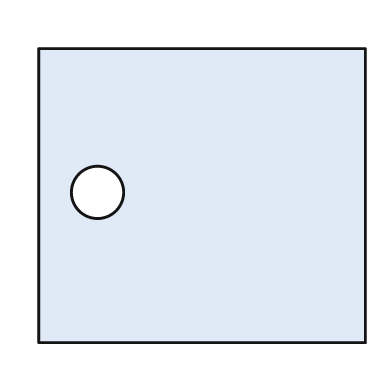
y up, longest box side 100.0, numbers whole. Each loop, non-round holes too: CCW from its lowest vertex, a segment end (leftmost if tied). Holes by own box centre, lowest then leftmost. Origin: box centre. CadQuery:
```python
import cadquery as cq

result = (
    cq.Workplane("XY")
    .moveTo(-50.0, -45.0)
    .lineTo(50.0, -45.0)
    .lineTo(50.0, 45.0)
    .lineTo(-50.0, 45.0)
    .close()
    .moveTo(-32.0, 1.0)
    .circle(8.0)
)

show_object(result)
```